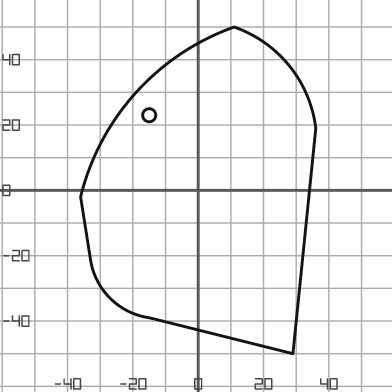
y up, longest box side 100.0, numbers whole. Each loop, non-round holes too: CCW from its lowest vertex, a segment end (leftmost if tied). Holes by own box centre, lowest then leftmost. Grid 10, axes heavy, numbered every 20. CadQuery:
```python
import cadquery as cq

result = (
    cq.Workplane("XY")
    .moveTo(29.0, -50.0)
    .lineTo(36.0, 19.0)
    .threePointArc((28.0, 38.0), (11.0, 50.0))
    .threePointArc((-19.0, 30.0), (-36.0, -2.0))
    .lineTo(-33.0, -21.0)
    .threePointArc((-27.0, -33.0), (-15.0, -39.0))
    .close()
    .moveTo(-15.0, 23.0)
    .circle(2.0)
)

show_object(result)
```